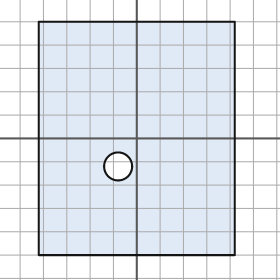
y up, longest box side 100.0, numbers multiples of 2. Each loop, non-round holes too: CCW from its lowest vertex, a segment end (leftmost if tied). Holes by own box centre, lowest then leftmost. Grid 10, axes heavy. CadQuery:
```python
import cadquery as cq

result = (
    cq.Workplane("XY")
    .moveTo(-42.0, -50.0)
    .lineTo(42.0, -50.0)
    .lineTo(42.0, 50.0)
    .lineTo(-42.0, 50.0)
    .close()
    .moveTo(-8.0, -12.0)
    .circle(6.0)
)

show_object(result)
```